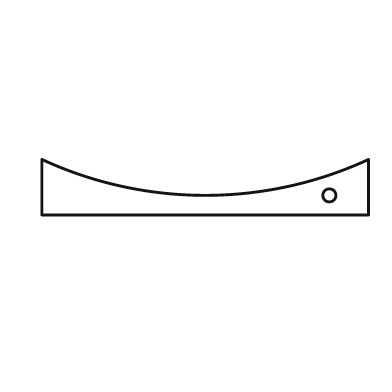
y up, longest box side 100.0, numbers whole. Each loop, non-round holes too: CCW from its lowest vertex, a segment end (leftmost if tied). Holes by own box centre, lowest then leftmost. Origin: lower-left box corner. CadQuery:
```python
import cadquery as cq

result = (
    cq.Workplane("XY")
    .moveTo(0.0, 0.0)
    .lineTo(100.0, 0.0)
    .lineTo(100.0, 17.0)
    .threePointArc((50.0, 6.0), (0.0, 17.0))
    .close()
    .moveTo(88.0, 6.0)
    .circle(2.0)
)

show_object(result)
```